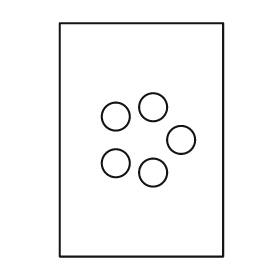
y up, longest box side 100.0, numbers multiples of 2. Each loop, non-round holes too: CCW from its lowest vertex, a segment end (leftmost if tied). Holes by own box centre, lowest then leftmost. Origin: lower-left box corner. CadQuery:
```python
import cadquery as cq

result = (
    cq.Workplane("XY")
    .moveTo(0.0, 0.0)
    .lineTo(70.0, 0.0)
    .lineTo(70.0, 100.0)
    .lineTo(0.0, 100.0)
    .close()
    .moveTo(40.0, 36.0)
    .circle(6.0)
    .moveTo(24.0, 40.0)
    .circle(6.0)
    .moveTo(52.0, 50.0)
    .circle(6.0)
    .moveTo(24.0, 60.0)
    .circle(6.0)
    .moveTo(40.0, 64.0)
    .circle(6.0)
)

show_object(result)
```